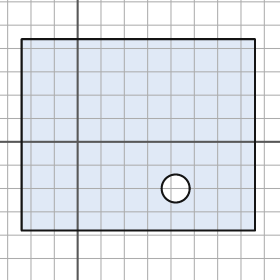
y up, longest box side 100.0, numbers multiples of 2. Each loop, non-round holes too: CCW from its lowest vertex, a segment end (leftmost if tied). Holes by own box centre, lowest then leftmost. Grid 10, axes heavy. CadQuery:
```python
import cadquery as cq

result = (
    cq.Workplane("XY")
    .moveTo(-24.0, -38.0)
    .lineTo(76.0, -38.0)
    .lineTo(76.0, 44.0)
    .lineTo(-24.0, 44.0)
    .close()
    .moveTo(42.0, -20.0)
    .circle(6.0)
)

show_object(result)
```